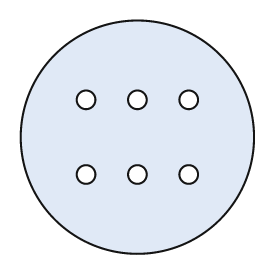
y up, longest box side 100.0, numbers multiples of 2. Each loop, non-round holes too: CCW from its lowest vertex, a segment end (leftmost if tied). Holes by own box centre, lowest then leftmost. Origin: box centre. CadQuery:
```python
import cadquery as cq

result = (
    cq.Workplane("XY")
    .moveTo(0.0, 0.0)
    .circle(50.0)
    .moveTo(-22.0, -16.0)
    .circle(4.0)
    .moveTo(0.0, -16.0)
    .circle(4.0)
    .moveTo(22.0, -16.0)
    .circle(4.0)
    .moveTo(-22.0, 16.0)
    .circle(4.0)
    .moveTo(0.0, 16.0)
    .circle(4.0)
    .moveTo(22.0, 16.0)
    .circle(4.0)
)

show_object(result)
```